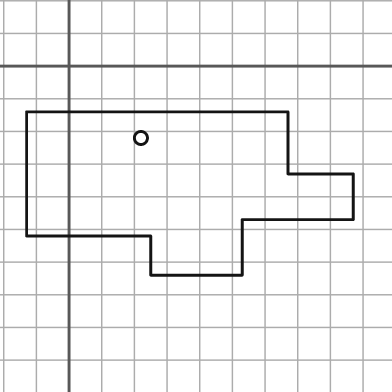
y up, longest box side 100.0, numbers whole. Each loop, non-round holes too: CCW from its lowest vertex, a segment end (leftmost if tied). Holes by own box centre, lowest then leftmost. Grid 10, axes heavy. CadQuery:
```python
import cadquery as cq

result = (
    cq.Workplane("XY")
    .moveTo(25.0, -64.0)
    .lineTo(53.0, -64.0)
    .lineTo(53.0, -47.0)
    .lineTo(87.0, -47.0)
    .lineTo(87.0, -33.0)
    .lineTo(67.0, -33.0)
    .lineTo(67.0, -14.0)
    .lineTo(-13.0, -14.0)
    .lineTo(-13.0, -52.0)
    .lineTo(25.0, -52.0)
    .close()
    .moveTo(22.0, -22.0)
    .circle(2.0)
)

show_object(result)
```